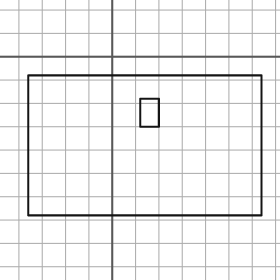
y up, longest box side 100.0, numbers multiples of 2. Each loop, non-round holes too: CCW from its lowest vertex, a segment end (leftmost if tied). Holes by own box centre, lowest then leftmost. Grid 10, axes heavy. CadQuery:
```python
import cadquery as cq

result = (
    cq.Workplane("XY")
    .moveTo(-36.0, -68.0)
    .lineTo(64.0, -68.0)
    .lineTo(64.0, -8.0)
    .lineTo(-36.0, -8.0)
    .close()
    .moveTo(12.0, -30.0)
    .lineTo(20.0, -30.0)
    .lineTo(20.0, -18.0)
    .lineTo(12.0, -18.0)
    .close()
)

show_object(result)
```